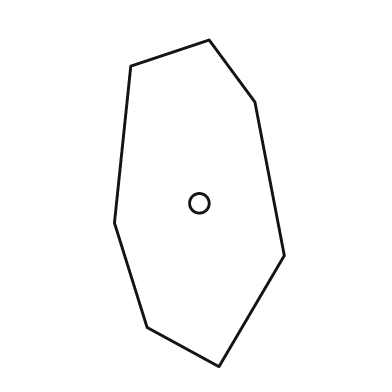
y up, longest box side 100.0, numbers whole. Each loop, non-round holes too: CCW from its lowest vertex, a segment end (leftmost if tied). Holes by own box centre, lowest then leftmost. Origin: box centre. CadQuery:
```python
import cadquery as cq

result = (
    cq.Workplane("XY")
    .moveTo(6.0, -50.0)
    .lineTo(26.0, -16.0)
    .lineTo(17.0, 31.0)
    .lineTo(3.0, 50.0)
    .lineTo(-21.0, 42.0)
    .lineTo(-26.0, -6.0)
    .lineTo(-16.0, -38.0)
    .close()
    .moveTo(0.0, 0.0)
    .circle(3.0)
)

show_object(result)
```